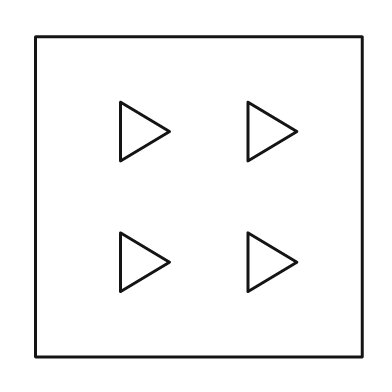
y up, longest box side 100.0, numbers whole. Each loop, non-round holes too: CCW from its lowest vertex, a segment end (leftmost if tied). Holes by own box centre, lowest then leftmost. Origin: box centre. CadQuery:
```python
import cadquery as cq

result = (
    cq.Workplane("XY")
    .moveTo(-50.0, -49.0)
    .lineTo(50.0, -49.0)
    .lineTo(50.0, 49.0)
    .lineTo(-50.0, 49.0)
    .close()
    .moveTo(-24.0, -29.0)
    .lineTo(-9.0, -20.0)
    .lineTo(-24.0, -11.0)
    .close()
    .moveTo(15.0, -29.0)
    .lineTo(30.0, -20.0)
    .lineTo(15.0, -11.0)
    .close()
    .moveTo(-24.0, 11.0)
    .lineTo(-9.0, 20.0)
    .lineTo(-24.0, 29.0)
    .close()
    .moveTo(15.0, 11.0)
    .lineTo(30.0, 20.0)
    .lineTo(15.0, 29.0)
    .close()
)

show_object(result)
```